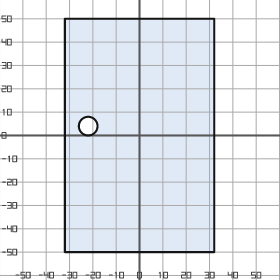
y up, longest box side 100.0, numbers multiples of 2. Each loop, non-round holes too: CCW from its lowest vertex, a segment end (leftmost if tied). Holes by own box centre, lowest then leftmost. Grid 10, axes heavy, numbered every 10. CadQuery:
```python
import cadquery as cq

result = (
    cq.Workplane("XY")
    .moveTo(-32.0, -50.0)
    .lineTo(32.0, -50.0)
    .lineTo(32.0, 50.0)
    .lineTo(-32.0, 50.0)
    .close()
    .moveTo(-22.0, 4.0)
    .circle(4.0)
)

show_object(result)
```